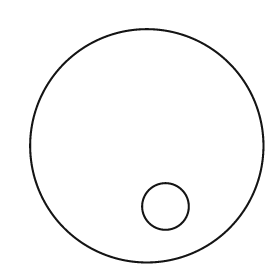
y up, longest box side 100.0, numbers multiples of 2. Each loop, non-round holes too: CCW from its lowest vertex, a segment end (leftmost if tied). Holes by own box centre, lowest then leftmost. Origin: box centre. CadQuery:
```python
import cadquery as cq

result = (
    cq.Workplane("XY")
    .moveTo(0.0, 0.0)
    .circle(50.0)
    .moveTo(8.0, -26.0)
    .circle(10.0)
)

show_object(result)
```